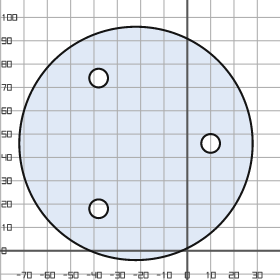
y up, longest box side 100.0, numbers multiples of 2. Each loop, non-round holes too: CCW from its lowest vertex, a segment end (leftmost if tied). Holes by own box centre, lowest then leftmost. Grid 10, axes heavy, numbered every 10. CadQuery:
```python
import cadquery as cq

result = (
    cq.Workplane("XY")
    .moveTo(-22.0, 46.0)
    .circle(50.0)
    .moveTo(-38.0, 18.0)
    .circle(4.0)
    .moveTo(10.0, 46.0)
    .circle(4.0)
    .moveTo(-38.0, 74.0)
    .circle(4.0)
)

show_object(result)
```